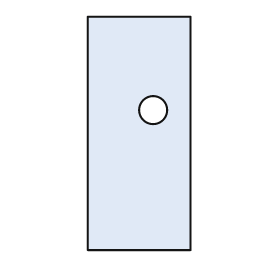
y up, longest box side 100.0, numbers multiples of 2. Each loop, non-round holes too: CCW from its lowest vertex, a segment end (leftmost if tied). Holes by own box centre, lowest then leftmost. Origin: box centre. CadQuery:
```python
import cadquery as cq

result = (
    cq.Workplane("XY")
    .moveTo(-22.0, -50.0)
    .lineTo(22.0, -50.0)
    .lineTo(22.0, 50.0)
    .lineTo(-22.0, 50.0)
    .close()
    .moveTo(6.0, 10.0)
    .circle(6.0)
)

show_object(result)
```